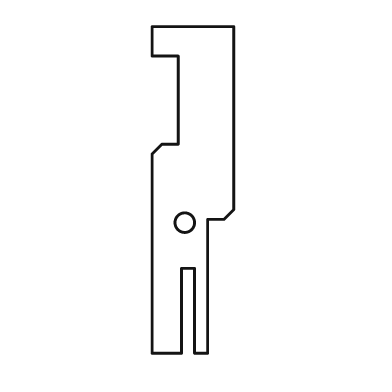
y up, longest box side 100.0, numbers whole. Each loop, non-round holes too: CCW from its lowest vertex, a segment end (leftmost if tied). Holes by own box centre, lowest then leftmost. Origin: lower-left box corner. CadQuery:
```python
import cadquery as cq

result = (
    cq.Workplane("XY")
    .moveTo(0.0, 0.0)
    .lineTo(9.0, 0.0)
    .lineTo(9.0, 26.0)
    .lineTo(13.0, 26.0)
    .lineTo(13.0, 0.0)
    .lineTo(17.0, 0.0)
    .lineTo(17.0, 41.0)
    .lineTo(22.0, 41.0)
    .lineTo(25.0, 44.0)
    .lineTo(25.0, 100.0)
    .lineTo(0.0, 100.0)
    .lineTo(0.0, 91.0)
    .lineTo(8.0, 91.0)
    .lineTo(8.0, 64.0)
    .lineTo(3.0, 64.0)
    .lineTo(0.0, 61.0)
    .close()
    .moveTo(10.0, 40.0)
    .circle(3.0)
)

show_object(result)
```